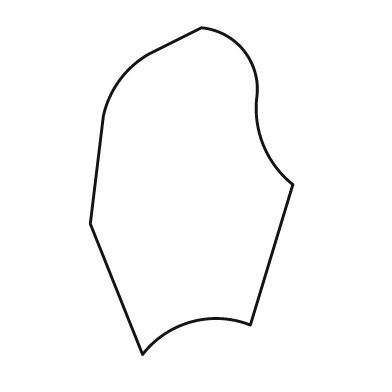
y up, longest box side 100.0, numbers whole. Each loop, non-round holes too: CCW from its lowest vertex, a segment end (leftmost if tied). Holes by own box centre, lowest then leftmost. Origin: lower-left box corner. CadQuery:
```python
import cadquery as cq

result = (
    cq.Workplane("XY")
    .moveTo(16.0, 0.0)
    .threePointArc((31.0, 10.0), (49.0, 9.0))
    .lineTo(62.0, 52.0)
    .threePointArc((53.0, 64.0), (51.0, 79.0))
    .threePointArc((47.0, 93.0), (34.0, 100.0))
    .lineTo(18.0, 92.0)
    .threePointArc((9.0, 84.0), (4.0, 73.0))
    .lineTo(0.0, 40.0)
    .close()
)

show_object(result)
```